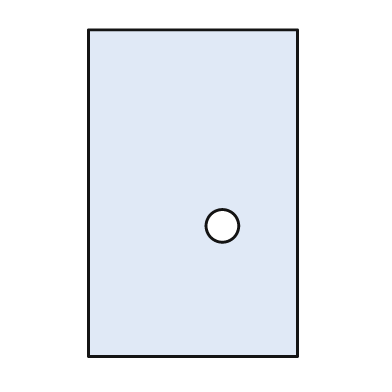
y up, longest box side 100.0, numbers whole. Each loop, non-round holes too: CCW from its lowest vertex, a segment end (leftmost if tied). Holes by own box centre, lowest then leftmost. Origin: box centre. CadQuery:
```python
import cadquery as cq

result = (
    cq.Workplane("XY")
    .moveTo(-32.0, -50.0)
    .lineTo(32.0, -50.0)
    .lineTo(32.0, 50.0)
    .lineTo(-32.0, 50.0)
    .close()
    .moveTo(9.0, -10.0)
    .circle(5.0)
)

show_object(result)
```